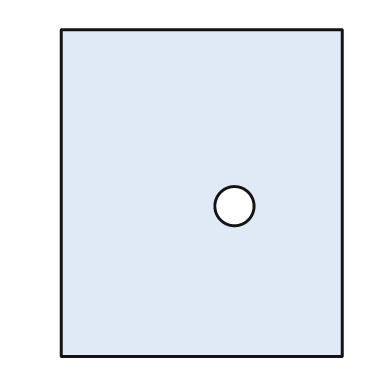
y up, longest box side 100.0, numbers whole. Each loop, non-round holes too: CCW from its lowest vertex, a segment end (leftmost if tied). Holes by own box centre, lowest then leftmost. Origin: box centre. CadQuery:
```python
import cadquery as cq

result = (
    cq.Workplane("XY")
    .moveTo(-43.0, -50.0)
    .lineTo(43.0, -50.0)
    .lineTo(43.0, 50.0)
    .lineTo(-43.0, 50.0)
    .close()
    .moveTo(10.0, -4.0)
    .circle(6.0)
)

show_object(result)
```